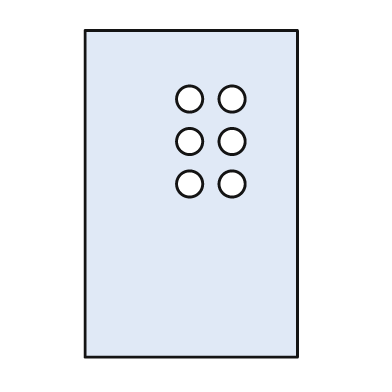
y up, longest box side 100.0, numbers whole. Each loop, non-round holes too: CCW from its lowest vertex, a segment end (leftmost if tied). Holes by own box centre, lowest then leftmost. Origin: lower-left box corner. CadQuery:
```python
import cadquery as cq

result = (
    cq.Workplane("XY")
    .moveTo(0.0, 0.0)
    .lineTo(65.0, 0.0)
    .lineTo(65.0, 100.0)
    .lineTo(0.0, 100.0)
    .close()
    .moveTo(32.0, 53.0)
    .circle(4.0)
    .moveTo(45.0, 53.0)
    .circle(4.0)
    .moveTo(32.0, 66.0)
    .circle(4.0)
    .moveTo(45.0, 66.0)
    .circle(4.0)
    .moveTo(32.0, 79.0)
    .circle(4.0)
    .moveTo(45.0, 79.0)
    .circle(4.0)
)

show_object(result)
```